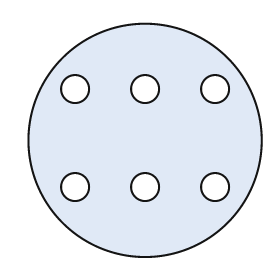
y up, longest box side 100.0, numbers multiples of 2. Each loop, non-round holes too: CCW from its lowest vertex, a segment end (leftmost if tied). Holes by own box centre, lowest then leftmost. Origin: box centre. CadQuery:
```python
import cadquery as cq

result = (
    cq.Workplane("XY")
    .moveTo(0.0, 0.0)
    .circle(50.0)
    .moveTo(-30.0, -20.0)
    .circle(6.0)
    .moveTo(0.0, -20.0)
    .circle(6.0)
    .moveTo(30.0, -20.0)
    .circle(6.0)
    .moveTo(-30.0, 22.0)
    .circle(6.0)
    .moveTo(0.0, 22.0)
    .circle(6.0)
    .moveTo(30.0, 22.0)
    .circle(6.0)
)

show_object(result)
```